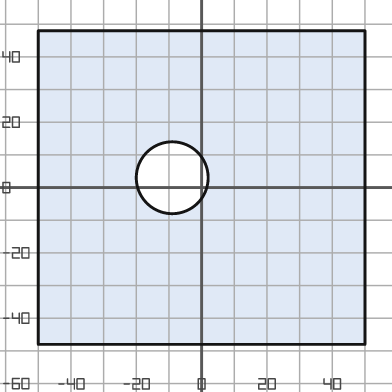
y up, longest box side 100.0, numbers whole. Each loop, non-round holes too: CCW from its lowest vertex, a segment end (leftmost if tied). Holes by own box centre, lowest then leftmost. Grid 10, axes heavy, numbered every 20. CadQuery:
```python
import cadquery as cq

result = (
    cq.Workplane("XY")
    .moveTo(-50.0, -48.0)
    .lineTo(50.0, -48.0)
    .lineTo(50.0, 48.0)
    .lineTo(-50.0, 48.0)
    .close()
    .moveTo(-9.0, 3.0)
    .circle(11.0)
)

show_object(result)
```